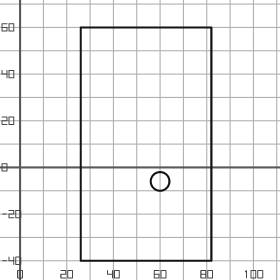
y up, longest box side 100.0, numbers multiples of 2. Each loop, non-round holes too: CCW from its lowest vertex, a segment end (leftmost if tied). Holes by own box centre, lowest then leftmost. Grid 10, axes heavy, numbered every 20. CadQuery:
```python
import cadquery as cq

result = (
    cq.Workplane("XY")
    .moveTo(26.0, -40.0)
    .lineTo(82.0, -40.0)
    .lineTo(82.0, 60.0)
    .lineTo(26.0, 60.0)
    .close()
    .moveTo(60.0, -6.0)
    .circle(4.0)
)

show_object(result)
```